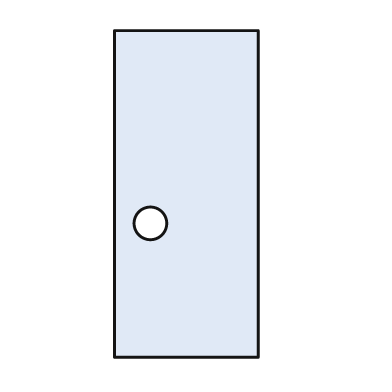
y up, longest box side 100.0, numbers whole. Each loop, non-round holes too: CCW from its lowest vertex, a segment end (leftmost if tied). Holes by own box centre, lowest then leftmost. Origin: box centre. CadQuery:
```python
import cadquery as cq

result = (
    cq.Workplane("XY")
    .moveTo(-22.0, -50.0)
    .lineTo(22.0, -50.0)
    .lineTo(22.0, 50.0)
    .lineTo(-22.0, 50.0)
    .close()
    .moveTo(-11.0, -9.0)
    .circle(5.0)
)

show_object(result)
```